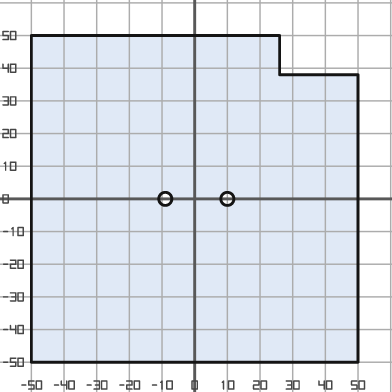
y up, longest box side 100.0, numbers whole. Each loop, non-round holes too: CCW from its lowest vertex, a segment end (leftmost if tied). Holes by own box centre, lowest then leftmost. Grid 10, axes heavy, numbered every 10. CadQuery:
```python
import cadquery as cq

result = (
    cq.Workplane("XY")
    .moveTo(-50.0, -50.0)
    .lineTo(50.0, -50.0)
    .lineTo(50.0, 38.0)
    .lineTo(26.0, 38.0)
    .lineTo(26.0, 50.0)
    .lineTo(-50.0, 50.0)
    .close()
    .moveTo(-9.0, 0.0)
    .circle(2.0)
    .moveTo(10.0, 0.0)
    .circle(2.0)
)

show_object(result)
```